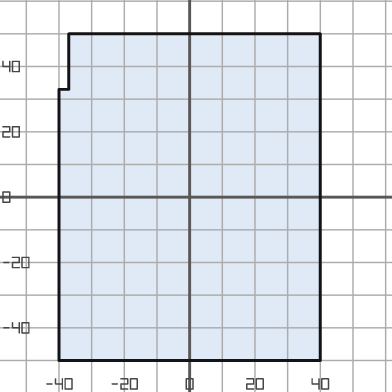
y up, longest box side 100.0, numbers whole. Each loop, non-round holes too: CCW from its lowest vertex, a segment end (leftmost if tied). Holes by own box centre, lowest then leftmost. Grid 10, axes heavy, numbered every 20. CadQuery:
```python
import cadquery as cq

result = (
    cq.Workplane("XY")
    .moveTo(-40.0, -50.0)
    .lineTo(40.0, -50.0)
    .lineTo(40.0, 50.0)
    .lineTo(-37.0, 50.0)
    .lineTo(-37.0, 33.0)
    .lineTo(-40.0, 33.0)
    .close()
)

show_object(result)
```